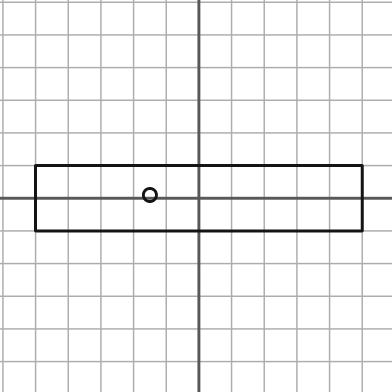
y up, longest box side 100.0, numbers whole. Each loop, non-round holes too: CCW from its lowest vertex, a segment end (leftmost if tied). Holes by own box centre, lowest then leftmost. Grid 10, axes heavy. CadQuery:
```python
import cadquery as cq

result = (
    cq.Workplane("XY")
    .moveTo(-50.0, -10.0)
    .lineTo(50.0, -10.0)
    .lineTo(50.0, 10.0)
    .lineTo(-50.0, 10.0)
    .close()
    .moveTo(-15.0, 1.0)
    .circle(2.0)
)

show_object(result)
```